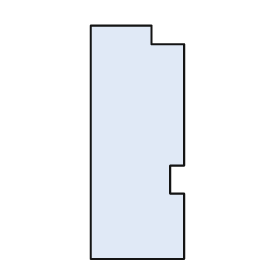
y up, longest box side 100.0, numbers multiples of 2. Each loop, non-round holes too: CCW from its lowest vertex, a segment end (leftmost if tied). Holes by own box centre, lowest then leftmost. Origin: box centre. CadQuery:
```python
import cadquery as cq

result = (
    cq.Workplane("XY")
    .moveTo(-20.0, -50.0)
    .lineTo(20.0, -50.0)
    .lineTo(20.0, -22.0)
    .lineTo(14.0, -22.0)
    .lineTo(14.0, -10.0)
    .lineTo(20.0, -10.0)
    .lineTo(20.0, 42.0)
    .lineTo(6.0, 42.0)
    .lineTo(6.0, 50.0)
    .lineTo(-20.0, 50.0)
    .close()
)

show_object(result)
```